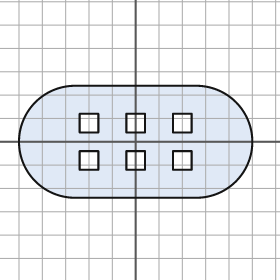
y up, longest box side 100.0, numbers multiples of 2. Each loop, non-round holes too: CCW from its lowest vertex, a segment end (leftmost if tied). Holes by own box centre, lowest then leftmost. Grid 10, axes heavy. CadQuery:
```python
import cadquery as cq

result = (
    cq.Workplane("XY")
    .moveTo(-26.0, -24.0)
    .lineTo(26.0, -24.0)
    .threePointArc((50.0, 0.0), (26.0, 24.0))
    .lineTo(-26.0, 24.0)
    .threePointArc((-50.0, 0.0), (-26.0, -24.0))
    .close()
    .moveTo(-24.0, -12.0)
    .lineTo(-16.0, -12.0)
    .lineTo(-16.0, -4.0)
    .lineTo(-24.0, -4.0)
    .close()
    .moveTo(-4.0, -12.0)
    .lineTo(4.0, -12.0)
    .lineTo(4.0, -4.0)
    .lineTo(-4.0, -4.0)
    .close()
    .moveTo(16.0, -12.0)
    .lineTo(24.0, -12.0)
    .lineTo(24.0, -4.0)
    .lineTo(16.0, -4.0)
    .close()
    .moveTo(-24.0, 4.0)
    .lineTo(-16.0, 4.0)
    .lineTo(-16.0, 12.0)
    .lineTo(-24.0, 12.0)
    .close()
    .moveTo(-4.0, 4.0)
    .lineTo(4.0, 4.0)
    .lineTo(4.0, 12.0)
    .lineTo(-4.0, 12.0)
    .close()
    .moveTo(16.0, 4.0)
    .lineTo(24.0, 4.0)
    .lineTo(24.0, 12.0)
    .lineTo(16.0, 12.0)
    .close()
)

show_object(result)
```